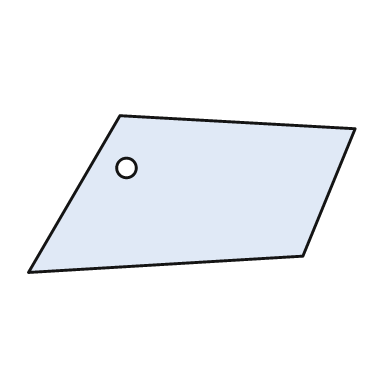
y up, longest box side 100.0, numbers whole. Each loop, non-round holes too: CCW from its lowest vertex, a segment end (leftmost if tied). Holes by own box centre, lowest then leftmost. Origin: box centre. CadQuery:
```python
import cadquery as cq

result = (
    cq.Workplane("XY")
    .moveTo(-50.0, -24.0)
    .lineTo(34.0, -19.0)
    .lineTo(50.0, 20.0)
    .lineTo(-22.0, 24.0)
    .close()
    .moveTo(-20.0, 8.0)
    .circle(3.0)
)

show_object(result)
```